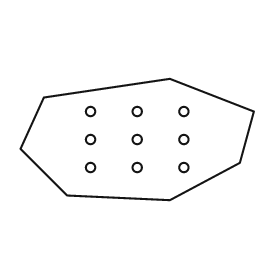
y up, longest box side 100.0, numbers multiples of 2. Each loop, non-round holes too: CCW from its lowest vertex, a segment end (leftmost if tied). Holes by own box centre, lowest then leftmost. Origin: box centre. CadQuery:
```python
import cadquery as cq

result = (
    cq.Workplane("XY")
    .moveTo(14.0, -26.0)
    .lineTo(44.0, -10.0)
    .lineTo(50.0, 12.0)
    .lineTo(14.0, 26.0)
    .lineTo(-40.0, 18.0)
    .lineTo(-50.0, -4.0)
    .lineTo(-30.0, -24.0)
    .close()
    .moveTo(-20.0, -12.0)
    .circle(2.0)
    .moveTo(0.0, -12.0)
    .circle(2.0)
    .moveTo(20.0, -12.0)
    .circle(2.0)
    .moveTo(-20.0, 0.0)
    .circle(2.0)
    .moveTo(0.0, 0.0)
    .circle(2.0)
    .moveTo(20.0, 0.0)
    .circle(2.0)
    .moveTo(-20.0, 12.0)
    .circle(2.0)
    .moveTo(0.0, 12.0)
    .circle(2.0)
    .moveTo(20.0, 12.0)
    .circle(2.0)
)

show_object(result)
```